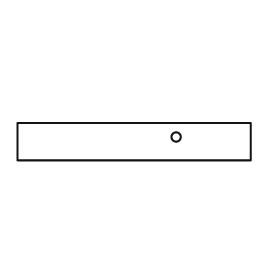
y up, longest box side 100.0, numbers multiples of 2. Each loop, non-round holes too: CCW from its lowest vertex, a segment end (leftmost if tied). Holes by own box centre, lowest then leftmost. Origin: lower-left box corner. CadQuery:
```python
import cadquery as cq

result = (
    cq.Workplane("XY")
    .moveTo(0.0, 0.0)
    .lineTo(100.0, 0.0)
    .lineTo(100.0, 16.0)
    .lineTo(0.0, 16.0)
    .close()
    .moveTo(68.0, 10.0)
    .circle(2.0)
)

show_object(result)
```